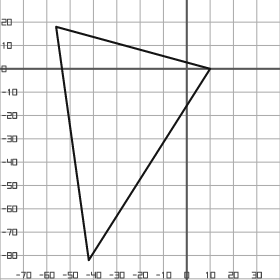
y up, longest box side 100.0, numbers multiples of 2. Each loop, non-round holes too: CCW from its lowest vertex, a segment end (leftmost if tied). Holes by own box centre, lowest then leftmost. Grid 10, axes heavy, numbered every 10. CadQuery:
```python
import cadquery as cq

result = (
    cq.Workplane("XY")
    .moveTo(-42.0, -82.0)
    .lineTo(10.0, 0.0)
    .lineTo(-56.0, 18.0)
    .close()
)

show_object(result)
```